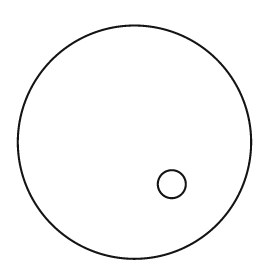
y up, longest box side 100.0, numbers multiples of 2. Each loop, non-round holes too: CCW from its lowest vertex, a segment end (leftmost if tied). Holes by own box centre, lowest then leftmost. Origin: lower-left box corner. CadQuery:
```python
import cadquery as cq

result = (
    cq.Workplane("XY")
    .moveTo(50.0, 50.0)
    .circle(50.0)
    .moveTo(66.0, 32.0)
    .circle(6.0)
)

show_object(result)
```